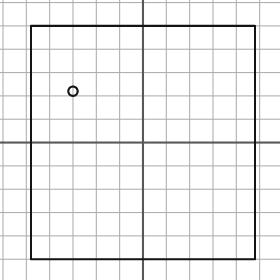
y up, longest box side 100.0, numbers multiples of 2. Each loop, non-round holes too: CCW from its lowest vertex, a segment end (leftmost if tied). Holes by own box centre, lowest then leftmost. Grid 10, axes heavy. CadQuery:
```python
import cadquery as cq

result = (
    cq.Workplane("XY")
    .moveTo(-48.0, -50.0)
    .lineTo(48.0, -50.0)
    .lineTo(48.0, 50.0)
    .lineTo(-48.0, 50.0)
    .close()
    .moveTo(-30.0, 22.0)
    .circle(2.0)
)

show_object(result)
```